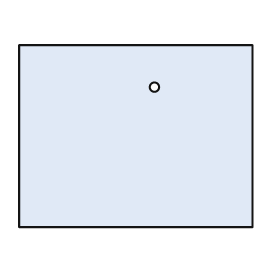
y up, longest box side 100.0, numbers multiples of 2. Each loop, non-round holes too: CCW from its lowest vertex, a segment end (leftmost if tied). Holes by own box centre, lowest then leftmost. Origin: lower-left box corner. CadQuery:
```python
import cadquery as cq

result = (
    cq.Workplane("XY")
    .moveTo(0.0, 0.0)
    .lineTo(100.0, 0.0)
    .lineTo(100.0, 78.0)
    .lineTo(0.0, 78.0)
    .close()
    .moveTo(58.0, 60.0)
    .circle(2.0)
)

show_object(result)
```